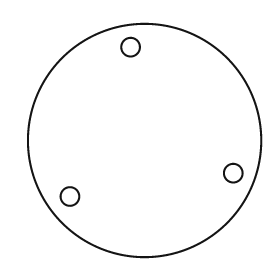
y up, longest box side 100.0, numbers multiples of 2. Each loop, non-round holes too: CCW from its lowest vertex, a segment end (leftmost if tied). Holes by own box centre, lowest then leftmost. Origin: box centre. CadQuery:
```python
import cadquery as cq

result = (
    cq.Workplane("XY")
    .moveTo(0.0, 0.0)
    .circle(50.0)
    .moveTo(-32.0, -24.0)
    .circle(4.0)
    .moveTo(38.0, -14.0)
    .circle(4.0)
    .moveTo(-6.0, 40.0)
    .circle(4.0)
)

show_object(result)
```